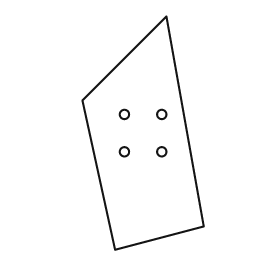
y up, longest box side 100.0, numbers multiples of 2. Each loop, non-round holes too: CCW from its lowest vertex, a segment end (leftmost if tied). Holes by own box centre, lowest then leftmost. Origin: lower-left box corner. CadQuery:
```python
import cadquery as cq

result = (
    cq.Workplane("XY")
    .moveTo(14.0, 0.0)
    .lineTo(52.0, 10.0)
    .lineTo(36.0, 100.0)
    .lineTo(0.0, 64.0)
    .close()
    .moveTo(18.0, 42.0)
    .circle(2.0)
    .moveTo(34.0, 42.0)
    .circle(2.0)
    .moveTo(18.0, 58.0)
    .circle(2.0)
    .moveTo(34.0, 58.0)
    .circle(2.0)
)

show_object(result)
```